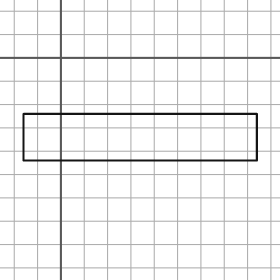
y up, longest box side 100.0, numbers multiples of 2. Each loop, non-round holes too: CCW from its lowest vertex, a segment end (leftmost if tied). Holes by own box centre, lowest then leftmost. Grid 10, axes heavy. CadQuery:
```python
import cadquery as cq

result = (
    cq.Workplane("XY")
    .moveTo(-16.0, -44.0)
    .lineTo(84.0, -44.0)
    .lineTo(84.0, -24.0)
    .lineTo(-16.0, -24.0)
    .close()
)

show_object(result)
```